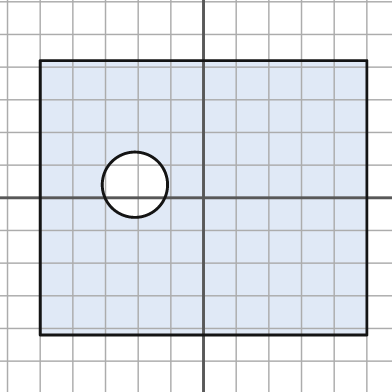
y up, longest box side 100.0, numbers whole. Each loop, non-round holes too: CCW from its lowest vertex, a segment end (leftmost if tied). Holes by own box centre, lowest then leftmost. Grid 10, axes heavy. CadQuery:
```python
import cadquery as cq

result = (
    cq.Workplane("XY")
    .moveTo(-50.0, -42.0)
    .lineTo(50.0, -42.0)
    .lineTo(50.0, 42.0)
    .lineTo(-50.0, 42.0)
    .close()
    .moveTo(-21.0, 4.0)
    .circle(10.0)
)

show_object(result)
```